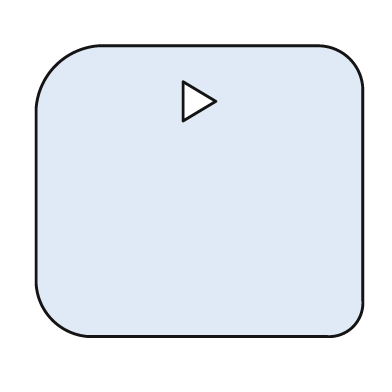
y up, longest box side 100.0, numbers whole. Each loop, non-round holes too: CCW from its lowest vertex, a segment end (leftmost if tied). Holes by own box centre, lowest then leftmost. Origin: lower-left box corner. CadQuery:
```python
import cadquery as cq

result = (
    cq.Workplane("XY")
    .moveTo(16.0, 0.0)
    .lineTo(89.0, 0.0)
    .threePointArc((97.0, 3.0), (100.0, 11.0))
    .lineTo(100.0, 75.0)
    .threePointArc((96.0, 85.0), (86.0, 89.0))
    .lineTo(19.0, 89.0)
    .threePointArc((6.0, 83.0), (0.0, 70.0))
    .lineTo(0.0, 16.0)
    .threePointArc((5.0, 5.0), (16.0, 0.0))
    .close()
    .moveTo(45.0, 66.0)
    .lineTo(55.0, 72.0)
    .lineTo(45.0, 78.0)
    .close()
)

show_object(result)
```